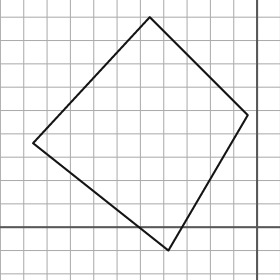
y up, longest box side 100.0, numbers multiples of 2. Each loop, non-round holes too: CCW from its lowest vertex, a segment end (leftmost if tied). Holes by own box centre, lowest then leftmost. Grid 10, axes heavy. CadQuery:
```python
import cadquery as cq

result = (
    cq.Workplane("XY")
    .moveTo(-38.0, -10.0)
    .lineTo(-4.0, 48.0)
    .lineTo(-46.0, 90.0)
    .lineTo(-96.0, 36.0)
    .close()
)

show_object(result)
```